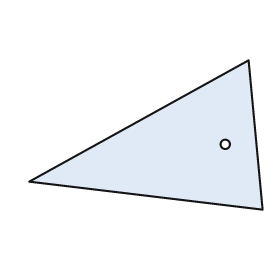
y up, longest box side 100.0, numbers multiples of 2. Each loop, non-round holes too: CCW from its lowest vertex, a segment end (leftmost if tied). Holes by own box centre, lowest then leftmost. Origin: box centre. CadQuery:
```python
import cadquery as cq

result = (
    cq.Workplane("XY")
    .moveTo(50.0, -32.0)
    .lineTo(44.0, 32.0)
    .lineTo(-50.0, -20.0)
    .close()
    .moveTo(34.0, -4.0)
    .circle(2.0)
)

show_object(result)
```